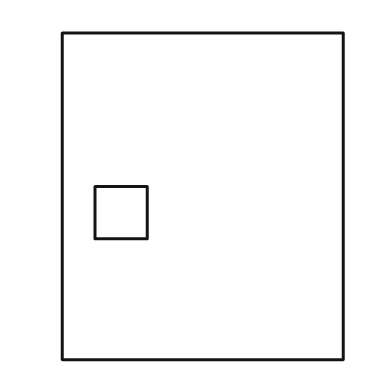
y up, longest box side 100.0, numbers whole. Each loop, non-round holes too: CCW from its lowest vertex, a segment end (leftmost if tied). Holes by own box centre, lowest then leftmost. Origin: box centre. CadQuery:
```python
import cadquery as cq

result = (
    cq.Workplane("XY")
    .moveTo(-43.0, -50.0)
    .lineTo(43.0, -50.0)
    .lineTo(43.0, 50.0)
    .lineTo(-43.0, 50.0)
    .close()
    .moveTo(-33.0, -13.0)
    .lineTo(-17.0, -13.0)
    .lineTo(-17.0, 3.0)
    .lineTo(-33.0, 3.0)
    .close()
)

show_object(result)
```